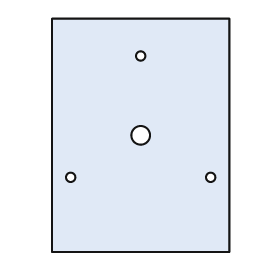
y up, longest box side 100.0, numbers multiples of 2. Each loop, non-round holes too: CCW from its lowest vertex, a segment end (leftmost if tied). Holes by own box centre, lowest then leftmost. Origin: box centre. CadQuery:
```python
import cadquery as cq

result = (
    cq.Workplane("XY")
    .moveTo(-38.0, -50.0)
    .lineTo(38.0, -50.0)
    .lineTo(38.0, 50.0)
    .lineTo(-38.0, 50.0)
    .close()
    .moveTo(-30.0, -18.0)
    .circle(2.0)
    .moveTo(30.0, -18.0)
    .circle(2.0)
    .moveTo(0.0, 0.0)
    .circle(4.0)
    .moveTo(0.0, 34.0)
    .circle(2.0)
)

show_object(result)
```